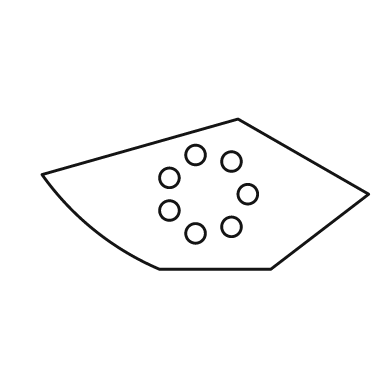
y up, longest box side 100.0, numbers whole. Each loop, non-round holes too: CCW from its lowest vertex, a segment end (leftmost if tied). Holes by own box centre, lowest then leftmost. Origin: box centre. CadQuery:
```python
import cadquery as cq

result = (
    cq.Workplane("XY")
    .moveTo(-14.0, -23.0)
    .lineTo(20.0, -23.0)
    .lineTo(50.0, 0.0)
    .lineTo(10.0, 23.0)
    .lineTo(-50.0, 6.0)
    .threePointArc((-34.0, -11.0), (-14.0, -23.0))
    .close()
    .moveTo(-3.0, -12.0)
    .circle(3.0)
    .moveTo(8.0, -10.0)
    .circle(3.0)
    .moveTo(-11.0, -5.0)
    .circle(3.0)
    .moveTo(13.0, 0.0)
    .circle(3.0)
    .moveTo(-11.0, 5.0)
    .circle(3.0)
    .moveTo(8.0, 10.0)
    .circle(3.0)
    .moveTo(-3.0, 12.0)
    .circle(3.0)
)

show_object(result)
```